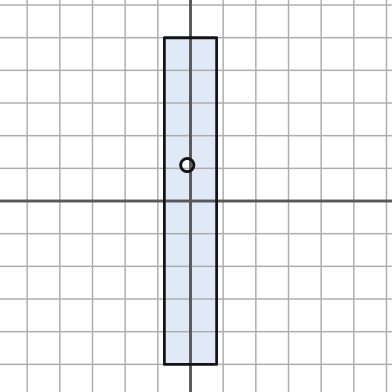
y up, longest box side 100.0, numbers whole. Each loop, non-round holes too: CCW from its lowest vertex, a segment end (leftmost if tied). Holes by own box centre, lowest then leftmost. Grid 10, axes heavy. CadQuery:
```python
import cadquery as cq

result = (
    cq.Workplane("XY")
    .moveTo(-8.0, -50.0)
    .lineTo(8.0, -50.0)
    .lineTo(8.0, 50.0)
    .lineTo(-8.0, 50.0)
    .close()
    .moveTo(-1.0, 11.0)
    .circle(2.0)
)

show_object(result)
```